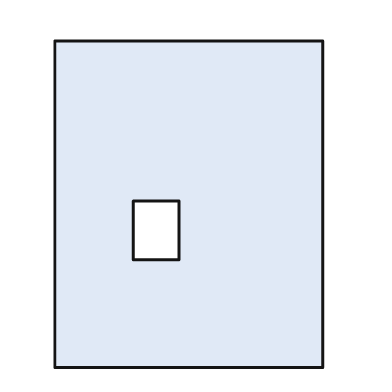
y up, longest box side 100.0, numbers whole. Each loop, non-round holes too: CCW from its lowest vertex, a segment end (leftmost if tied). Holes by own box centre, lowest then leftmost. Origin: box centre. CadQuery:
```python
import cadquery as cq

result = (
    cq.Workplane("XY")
    .moveTo(-41.0, -50.0)
    .lineTo(41.0, -50.0)
    .lineTo(41.0, 50.0)
    .lineTo(-41.0, 50.0)
    .close()
    .moveTo(-17.0, -17.0)
    .lineTo(-3.0, -17.0)
    .lineTo(-3.0, 1.0)
    .lineTo(-17.0, 1.0)
    .close()
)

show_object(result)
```